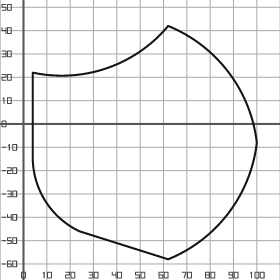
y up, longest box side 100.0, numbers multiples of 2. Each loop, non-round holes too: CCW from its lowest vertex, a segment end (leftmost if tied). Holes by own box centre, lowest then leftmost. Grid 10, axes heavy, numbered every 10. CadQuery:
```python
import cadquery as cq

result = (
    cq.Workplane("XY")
    .moveTo(62.0, -58.0)
    .threePointArc((88.0, -38.0), (100.0, -8.0))
    .threePointArc((88.0, 22.0), (62.0, 42.0))
    .threePointArc((36.0, 24.0), (4.0, 22.0))
    .lineTo(4.0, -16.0)
    .threePointArc((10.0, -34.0), (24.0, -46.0))
    .close()
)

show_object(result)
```